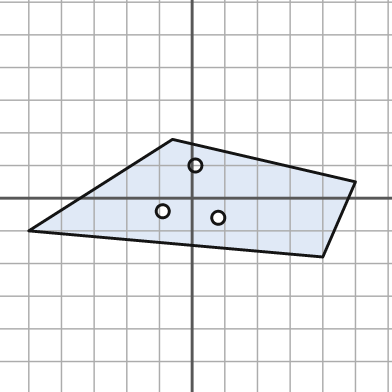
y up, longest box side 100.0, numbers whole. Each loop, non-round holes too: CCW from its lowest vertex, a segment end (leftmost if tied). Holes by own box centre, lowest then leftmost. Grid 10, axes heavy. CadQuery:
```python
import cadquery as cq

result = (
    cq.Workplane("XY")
    .moveTo(40.0, -18.0)
    .lineTo(50.0, 5.0)
    .lineTo(-6.0, 18.0)
    .lineTo(-50.0, -10.0)
    .close()
    .moveTo(8.0, -6.0)
    .circle(2.0)
    .moveTo(-9.0, -4.0)
    .circle(2.0)
    .moveTo(1.0, 10.0)
    .circle(2.0)
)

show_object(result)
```